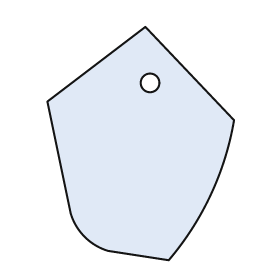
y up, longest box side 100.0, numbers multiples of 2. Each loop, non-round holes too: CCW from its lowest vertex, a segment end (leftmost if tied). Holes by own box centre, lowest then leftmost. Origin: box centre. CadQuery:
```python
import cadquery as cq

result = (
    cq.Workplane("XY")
    .moveTo(12.0, -50.0)
    .threePointArc((30.0, -22.0), (40.0, 10.0))
    .lineTo(2.0, 50.0)
    .lineTo(-40.0, 18.0)
    .lineTo(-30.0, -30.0)
    .threePointArc((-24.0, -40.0), (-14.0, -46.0))
    .close()
    .moveTo(4.0, 26.0)
    .circle(4.0)
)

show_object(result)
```